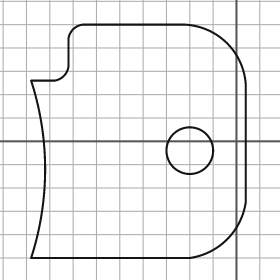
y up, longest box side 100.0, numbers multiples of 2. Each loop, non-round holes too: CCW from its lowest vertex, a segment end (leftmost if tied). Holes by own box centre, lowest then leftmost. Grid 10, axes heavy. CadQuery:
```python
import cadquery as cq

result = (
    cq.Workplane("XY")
    .moveTo(-88.0, -50.0)
    .lineTo(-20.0, -50.0)
    .threePointArc((-4.0, -42.0), (4.0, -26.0))
    .lineTo(4.0, 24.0)
    .threePointArc((-4.0, 42.0), (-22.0, 50.0))
    .lineTo(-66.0, 50.0)
    .threePointArc((-70.0, 48.0), (-72.0, 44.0))
    .lineTo(-72.0, 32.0)
    .threePointArc((-74.0, 28.0), (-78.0, 26.0))
    .lineTo(-88.0, 26.0)
    .threePointArc((-82.0, -12.0), (-88.0, -50.0))
    .close()
    .moveTo(-20.0, -4.0)
    .circle(10.0)
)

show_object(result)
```